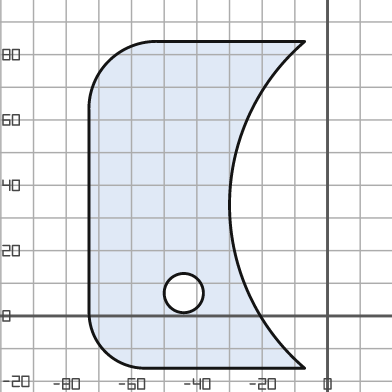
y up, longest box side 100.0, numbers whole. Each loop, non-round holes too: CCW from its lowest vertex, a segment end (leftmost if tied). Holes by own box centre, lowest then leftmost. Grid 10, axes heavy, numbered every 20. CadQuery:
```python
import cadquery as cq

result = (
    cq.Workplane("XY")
    .moveTo(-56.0, -16.0)
    .lineTo(-7.0, -16.0)
    .threePointArc((-30.0, 34.0), (-7.0, 84.0))
    .lineTo(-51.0, 84.0)
    .threePointArc((-67.0, 78.0), (-73.0, 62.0))
    .lineTo(-73.0, 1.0)
    .threePointArc((-68.0, -11.0), (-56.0, -16.0))
    .close()
    .moveTo(-44.0, 7.0)
    .circle(6.0)
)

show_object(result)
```